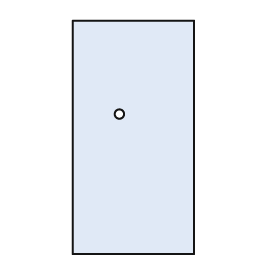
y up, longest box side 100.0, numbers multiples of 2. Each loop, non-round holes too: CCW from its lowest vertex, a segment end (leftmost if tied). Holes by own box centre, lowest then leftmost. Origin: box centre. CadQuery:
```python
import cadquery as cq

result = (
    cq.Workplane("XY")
    .moveTo(-26.0, -50.0)
    .lineTo(26.0, -50.0)
    .lineTo(26.0, 50.0)
    .lineTo(-26.0, 50.0)
    .close()
    .moveTo(-6.0, 10.0)
    .circle(2.0)
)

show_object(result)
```